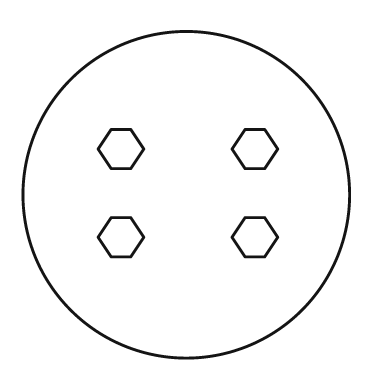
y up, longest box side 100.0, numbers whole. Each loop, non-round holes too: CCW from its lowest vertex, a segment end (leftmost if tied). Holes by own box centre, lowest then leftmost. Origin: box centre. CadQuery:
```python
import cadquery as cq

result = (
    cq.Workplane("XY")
    .moveTo(0.0, 0.0)
    .circle(50.0)
    .moveTo(-23.0, -19.0)
    .lineTo(-17.0, -19.0)
    .lineTo(-13.0, -13.0)
    .lineTo(-17.0, -7.0)
    .lineTo(-23.0, -7.0)
    .lineTo(-27.0, -13.0)
    .close()
    .moveTo(18.0, -19.0)
    .lineTo(24.0, -19.0)
    .lineTo(28.0, -13.0)
    .lineTo(24.0, -7.0)
    .lineTo(18.0, -7.0)
    .lineTo(14.0, -13.0)
    .close()
    .moveTo(-23.0, 8.0)
    .lineTo(-17.0, 8.0)
    .lineTo(-13.0, 14.0)
    .lineTo(-17.0, 20.0)
    .lineTo(-23.0, 20.0)
    .lineTo(-27.0, 14.0)
    .close()
    .moveTo(18.0, 8.0)
    .lineTo(24.0, 8.0)
    .lineTo(28.0, 14.0)
    .lineTo(24.0, 20.0)
    .lineTo(18.0, 20.0)
    .lineTo(14.0, 14.0)
    .close()
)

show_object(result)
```